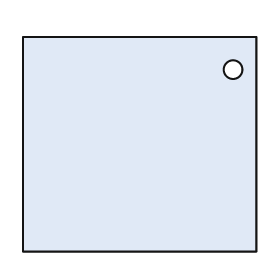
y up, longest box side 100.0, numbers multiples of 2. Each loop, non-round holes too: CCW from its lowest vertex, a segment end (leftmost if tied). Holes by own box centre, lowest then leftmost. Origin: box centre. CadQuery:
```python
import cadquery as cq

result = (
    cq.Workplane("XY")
    .moveTo(-50.0, -46.0)
    .lineTo(50.0, -46.0)
    .lineTo(50.0, 46.0)
    .lineTo(-50.0, 46.0)
    .close()
    .moveTo(40.0, 32.0)
    .circle(4.0)
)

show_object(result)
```